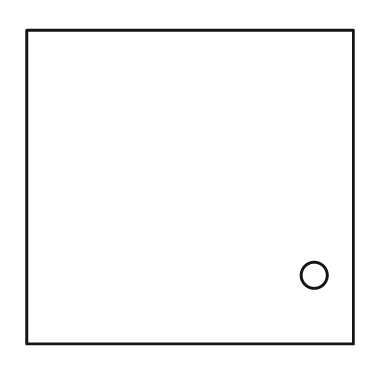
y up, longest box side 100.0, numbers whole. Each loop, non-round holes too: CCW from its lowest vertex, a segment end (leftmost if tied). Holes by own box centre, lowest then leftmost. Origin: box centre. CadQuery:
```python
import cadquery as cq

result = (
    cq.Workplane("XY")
    .moveTo(-50.0, -48.0)
    .lineTo(50.0, -48.0)
    .lineTo(50.0, 48.0)
    .lineTo(-50.0, 48.0)
    .close()
    .moveTo(38.0, -27.0)
    .circle(4.0)
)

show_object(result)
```